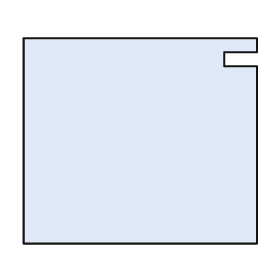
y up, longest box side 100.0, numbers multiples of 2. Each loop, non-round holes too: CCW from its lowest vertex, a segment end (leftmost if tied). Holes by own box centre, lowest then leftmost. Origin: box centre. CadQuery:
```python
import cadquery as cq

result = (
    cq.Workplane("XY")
    .moveTo(-50.0, -44.0)
    .lineTo(50.0, -44.0)
    .lineTo(50.0, 32.0)
    .lineTo(36.0, 32.0)
    .lineTo(36.0, 38.0)
    .lineTo(50.0, 38.0)
    .lineTo(50.0, 44.0)
    .lineTo(-50.0, 44.0)
    .close()
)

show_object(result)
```